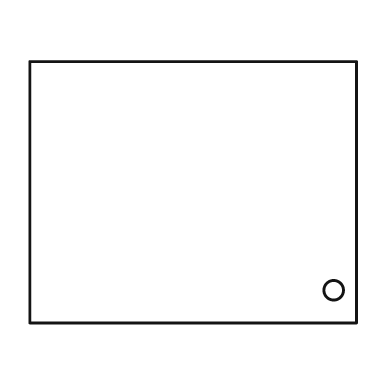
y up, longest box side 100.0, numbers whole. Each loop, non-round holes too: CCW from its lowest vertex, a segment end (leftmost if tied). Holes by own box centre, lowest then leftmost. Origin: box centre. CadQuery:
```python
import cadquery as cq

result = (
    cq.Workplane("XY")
    .moveTo(-50.0, -40.0)
    .lineTo(50.0, -40.0)
    .lineTo(50.0, 40.0)
    .lineTo(-50.0, 40.0)
    .close()
    .moveTo(43.0, -30.0)
    .circle(3.0)
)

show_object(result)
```